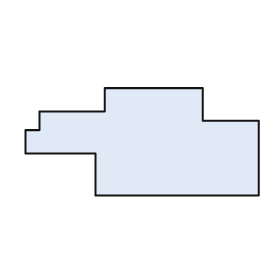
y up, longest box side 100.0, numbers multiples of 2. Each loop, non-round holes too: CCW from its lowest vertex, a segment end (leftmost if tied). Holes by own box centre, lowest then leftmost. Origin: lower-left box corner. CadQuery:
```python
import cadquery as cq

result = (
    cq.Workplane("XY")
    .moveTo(30.0, 0.0)
    .lineTo(100.0, 0.0)
    .lineTo(100.0, 32.0)
    .lineTo(76.0, 32.0)
    .lineTo(76.0, 46.0)
    .lineTo(34.0, 46.0)
    .lineTo(34.0, 36.0)
    .lineTo(6.0, 36.0)
    .lineTo(6.0, 28.0)
    .lineTo(0.0, 28.0)
    .lineTo(0.0, 18.0)
    .lineTo(30.0, 18.0)
    .close()
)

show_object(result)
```